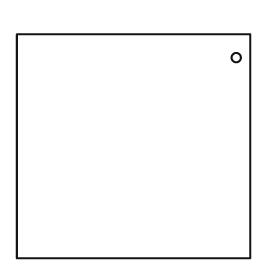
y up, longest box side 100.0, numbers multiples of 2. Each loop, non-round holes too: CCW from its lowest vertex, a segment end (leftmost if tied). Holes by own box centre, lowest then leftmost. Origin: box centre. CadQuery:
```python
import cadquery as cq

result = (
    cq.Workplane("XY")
    .moveTo(-50.0, -48.0)
    .lineTo(50.0, -48.0)
    .lineTo(50.0, 48.0)
    .lineTo(-50.0, 48.0)
    .close()
    .moveTo(44.0, 38.0)
    .circle(2.0)
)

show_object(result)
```